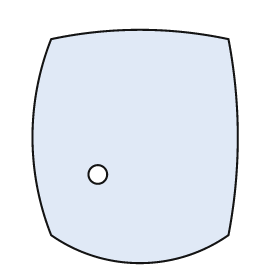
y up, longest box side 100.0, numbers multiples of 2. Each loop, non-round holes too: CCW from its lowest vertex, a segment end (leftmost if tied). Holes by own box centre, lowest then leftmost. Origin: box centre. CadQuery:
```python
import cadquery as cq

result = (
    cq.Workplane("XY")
    .moveTo(-36.0, -38.0)
    .threePointArc((2.0, -50.0), (40.0, -38.0))
    .threePointArc((44.0, 4.0), (40.0, 46.0))
    .threePointArc((2.0, 50.0), (-36.0, 46.0))
    .threePointArc((-44.0, 4.0), (-36.0, -38.0))
    .close()
    .moveTo(-16.0, -12.0)
    .circle(4.0)
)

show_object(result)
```